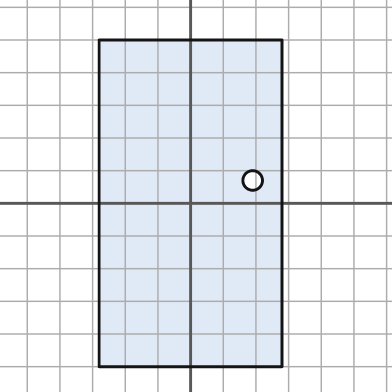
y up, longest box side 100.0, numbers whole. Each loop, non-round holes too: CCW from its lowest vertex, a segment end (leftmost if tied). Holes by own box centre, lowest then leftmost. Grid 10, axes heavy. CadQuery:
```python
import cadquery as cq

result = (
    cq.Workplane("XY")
    .moveTo(-28.0, -50.0)
    .lineTo(28.0, -50.0)
    .lineTo(28.0, 50.0)
    .lineTo(-28.0, 50.0)
    .close()
    .moveTo(19.0, 7.0)
    .circle(3.0)
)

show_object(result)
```